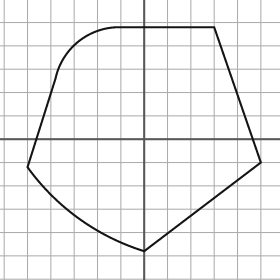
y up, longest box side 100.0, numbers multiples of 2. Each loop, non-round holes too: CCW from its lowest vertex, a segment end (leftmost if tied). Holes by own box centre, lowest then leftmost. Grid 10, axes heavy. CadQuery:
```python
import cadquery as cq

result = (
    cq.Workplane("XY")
    .moveTo(0.0, -48.0)
    .lineTo(50.0, -10.0)
    .lineTo(30.0, 48.0)
    .lineTo(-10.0, 48.0)
    .threePointArc((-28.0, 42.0), (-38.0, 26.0))
    .lineTo(-50.0, -12.0)
    .threePointArc((-28.0, -34.0), (0.0, -48.0))
    .close()
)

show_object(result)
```